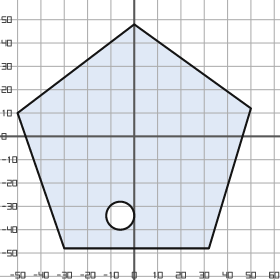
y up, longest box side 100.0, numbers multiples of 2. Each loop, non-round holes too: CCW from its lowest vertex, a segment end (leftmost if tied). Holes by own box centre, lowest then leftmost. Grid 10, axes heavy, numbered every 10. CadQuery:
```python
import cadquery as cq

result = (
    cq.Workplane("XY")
    .moveTo(-30.0, -48.0)
    .lineTo(32.0, -48.0)
    .lineTo(50.0, 12.0)
    .lineTo(0.0, 48.0)
    .lineTo(-50.0, 10.0)
    .close()
    .moveTo(-6.0, -34.0)
    .circle(6.0)
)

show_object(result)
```